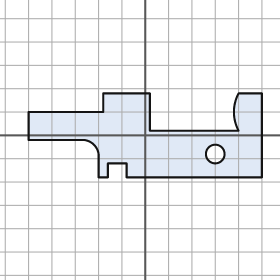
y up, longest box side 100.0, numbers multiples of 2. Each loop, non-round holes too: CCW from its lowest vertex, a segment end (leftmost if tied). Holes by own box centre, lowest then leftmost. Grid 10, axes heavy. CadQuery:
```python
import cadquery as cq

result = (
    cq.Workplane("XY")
    .moveTo(-20.0, -18.0)
    .lineTo(-16.0, -18.0)
    .lineTo(-16.0, -12.0)
    .lineTo(-8.0, -12.0)
    .lineTo(-8.0, -18.0)
    .lineTo(50.0, -18.0)
    .lineTo(50.0, 18.0)
    .lineTo(40.0, 18.0)
    .threePointArc((38.0, 10.0), (40.0, 2.0))
    .lineTo(2.0, 2.0)
    .lineTo(2.0, 18.0)
    .lineTo(-18.0, 18.0)
    .lineTo(-18.0, 10.0)
    .lineTo(-50.0, 10.0)
    .lineTo(-50.0, -2.0)
    .lineTo(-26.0, -2.0)
    .threePointArc((-22.0, -4.0), (-20.0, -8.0))
    .close()
    .moveTo(30.0, -8.0)
    .circle(4.0)
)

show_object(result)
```